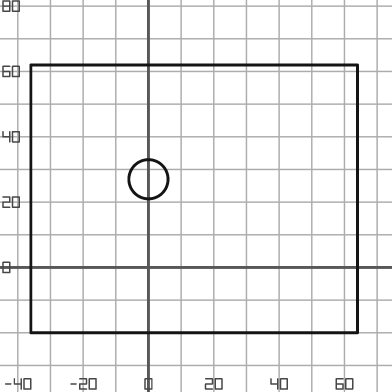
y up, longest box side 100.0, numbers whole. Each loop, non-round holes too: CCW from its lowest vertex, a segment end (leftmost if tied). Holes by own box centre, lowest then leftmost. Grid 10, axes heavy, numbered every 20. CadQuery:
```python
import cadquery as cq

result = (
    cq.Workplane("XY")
    .moveTo(-36.0, -20.0)
    .lineTo(64.0, -20.0)
    .lineTo(64.0, 62.0)
    .lineTo(-36.0, 62.0)
    .close()
    .moveTo(0.0, 27.0)
    .circle(6.0)
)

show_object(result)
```